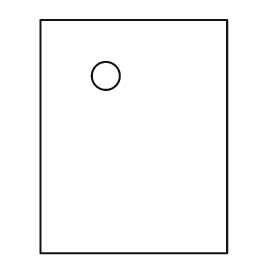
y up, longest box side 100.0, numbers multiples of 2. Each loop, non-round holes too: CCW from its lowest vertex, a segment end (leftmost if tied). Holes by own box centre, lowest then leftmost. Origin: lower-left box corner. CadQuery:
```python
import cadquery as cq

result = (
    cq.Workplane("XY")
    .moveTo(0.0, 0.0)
    .lineTo(80.0, 0.0)
    .lineTo(80.0, 100.0)
    .lineTo(0.0, 100.0)
    .close()
    .moveTo(28.0, 76.0)
    .circle(6.0)
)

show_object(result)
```